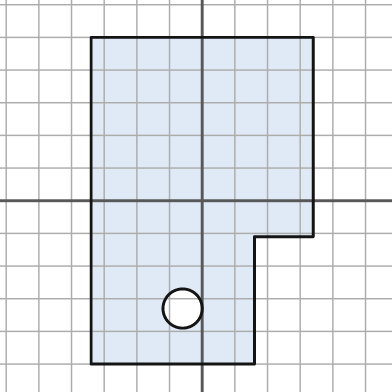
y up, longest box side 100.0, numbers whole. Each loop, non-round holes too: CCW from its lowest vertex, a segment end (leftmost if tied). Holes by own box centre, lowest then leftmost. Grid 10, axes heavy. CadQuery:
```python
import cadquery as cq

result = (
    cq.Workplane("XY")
    .moveTo(-34.0, -50.0)
    .lineTo(16.0, -50.0)
    .lineTo(16.0, -11.0)
    .lineTo(34.0, -11.0)
    .lineTo(34.0, 50.0)
    .lineTo(-34.0, 50.0)
    .close()
    .moveTo(-6.0, -33.0)
    .circle(6.0)
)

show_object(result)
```